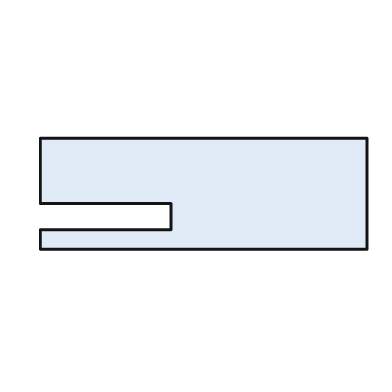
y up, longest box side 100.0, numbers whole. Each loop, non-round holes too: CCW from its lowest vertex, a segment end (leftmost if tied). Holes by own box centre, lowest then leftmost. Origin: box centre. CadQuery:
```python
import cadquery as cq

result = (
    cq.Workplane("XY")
    .moveTo(-50.0, -17.0)
    .lineTo(50.0, -17.0)
    .lineTo(50.0, 17.0)
    .lineTo(-50.0, 17.0)
    .lineTo(-50.0, -3.0)
    .lineTo(-10.0, -3.0)
    .lineTo(-10.0, -11.0)
    .lineTo(-50.0, -11.0)
    .close()
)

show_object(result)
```